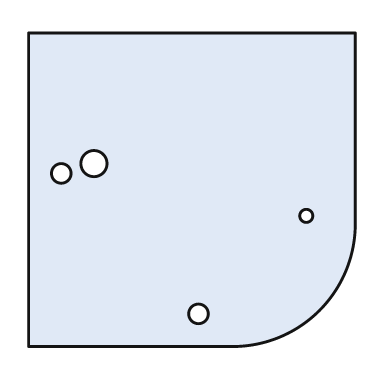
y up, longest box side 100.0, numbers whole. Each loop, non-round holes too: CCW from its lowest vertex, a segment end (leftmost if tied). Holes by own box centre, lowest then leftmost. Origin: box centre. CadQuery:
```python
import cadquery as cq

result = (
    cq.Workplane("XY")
    .moveTo(-50.0, -48.0)
    .lineTo(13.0, -48.0)
    .threePointArc((39.0, -37.0), (50.0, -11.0))
    .lineTo(50.0, 48.0)
    .lineTo(-50.0, 48.0)
    .close()
    .moveTo(2.0, -38.0)
    .circle(3.0)
    .moveTo(35.0, -8.0)
    .circle(2.0)
    .moveTo(-40.0, 5.0)
    .circle(3.0)
    .moveTo(-30.0, 8.0)
    .circle(4.0)
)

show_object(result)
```